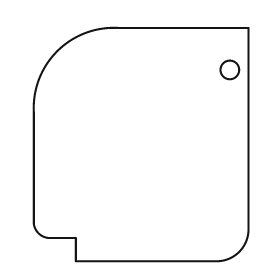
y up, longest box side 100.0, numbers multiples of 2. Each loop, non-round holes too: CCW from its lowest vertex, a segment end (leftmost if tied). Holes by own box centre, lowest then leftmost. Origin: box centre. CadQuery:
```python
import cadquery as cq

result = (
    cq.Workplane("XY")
    .moveTo(-28.0, -50.0)
    .lineTo(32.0, -50.0)
    .threePointArc((42.0, -46.0), (46.0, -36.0))
    .lineTo(46.0, 50.0)
    .lineTo(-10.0, 50.0)
    .threePointArc((-36.0, 40.0), (-46.0, 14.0))
    .lineTo(-46.0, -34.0)
    .threePointArc((-44.0, -38.0), (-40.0, -40.0))
    .lineTo(-28.0, -40.0)
    .close()
    .moveTo(38.0, 32.0)
    .circle(4.0)
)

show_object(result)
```